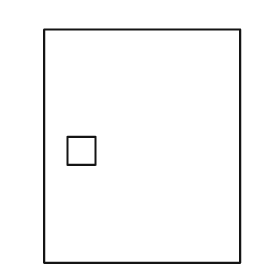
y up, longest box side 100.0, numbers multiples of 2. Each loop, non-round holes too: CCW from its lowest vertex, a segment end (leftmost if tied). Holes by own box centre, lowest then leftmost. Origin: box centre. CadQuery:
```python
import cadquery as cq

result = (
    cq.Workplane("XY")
    .moveTo(-42.0, -50.0)
    .lineTo(42.0, -50.0)
    .lineTo(42.0, 50.0)
    .lineTo(-42.0, 50.0)
    .close()
    .moveTo(-32.0, -8.0)
    .lineTo(-20.0, -8.0)
    .lineTo(-20.0, 4.0)
    .lineTo(-32.0, 4.0)
    .close()
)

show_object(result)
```